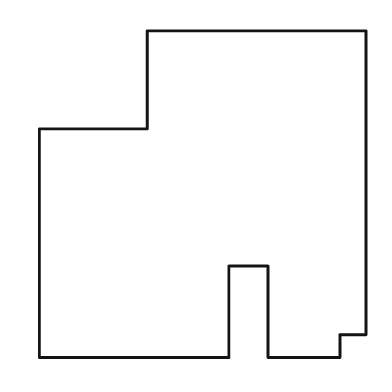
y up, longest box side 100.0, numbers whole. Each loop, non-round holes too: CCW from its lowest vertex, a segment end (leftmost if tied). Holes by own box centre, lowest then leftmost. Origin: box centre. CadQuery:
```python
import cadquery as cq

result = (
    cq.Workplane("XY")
    .moveTo(-50.0, -50.0)
    .lineTo(8.0, -50.0)
    .lineTo(8.0, -22.0)
    .lineTo(20.0, -22.0)
    .lineTo(20.0, -50.0)
    .lineTo(42.0, -50.0)
    .lineTo(42.0, -43.0)
    .lineTo(50.0, -43.0)
    .lineTo(50.0, 50.0)
    .lineTo(-17.0, 50.0)
    .lineTo(-17.0, 20.0)
    .lineTo(-50.0, 20.0)
    .close()
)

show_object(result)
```